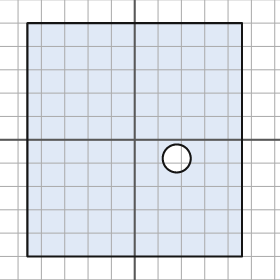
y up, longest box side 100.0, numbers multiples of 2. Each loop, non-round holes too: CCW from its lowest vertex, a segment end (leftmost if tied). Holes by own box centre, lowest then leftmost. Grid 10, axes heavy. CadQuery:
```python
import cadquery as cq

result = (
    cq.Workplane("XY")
    .moveTo(-46.0, -50.0)
    .lineTo(46.0, -50.0)
    .lineTo(46.0, 50.0)
    .lineTo(-46.0, 50.0)
    .close()
    .moveTo(18.0, -8.0)
    .circle(6.0)
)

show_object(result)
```